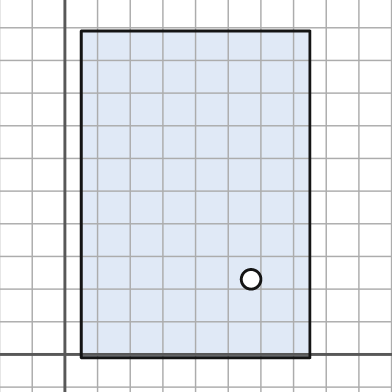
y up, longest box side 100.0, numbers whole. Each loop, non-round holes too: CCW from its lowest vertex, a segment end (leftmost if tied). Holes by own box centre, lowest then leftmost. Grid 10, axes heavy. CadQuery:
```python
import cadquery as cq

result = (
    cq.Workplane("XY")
    .moveTo(5.0, -1.0)
    .lineTo(75.0, -1.0)
    .lineTo(75.0, 99.0)
    .lineTo(5.0, 99.0)
    .close()
    .moveTo(57.0, 23.0)
    .circle(3.0)
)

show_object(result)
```